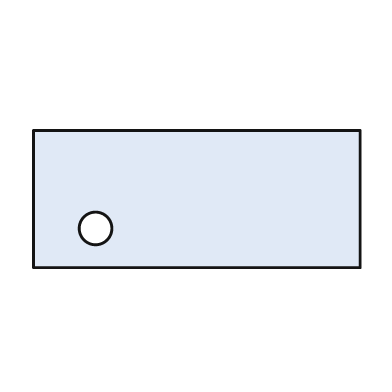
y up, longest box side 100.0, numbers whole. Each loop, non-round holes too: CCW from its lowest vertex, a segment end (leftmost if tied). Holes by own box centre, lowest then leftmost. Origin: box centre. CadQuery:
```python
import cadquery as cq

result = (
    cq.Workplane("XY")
    .moveTo(-50.0, -21.0)
    .lineTo(50.0, -21.0)
    .lineTo(50.0, 21.0)
    .lineTo(-50.0, 21.0)
    .close()
    .moveTo(-31.0, -9.0)
    .circle(5.0)
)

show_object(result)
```